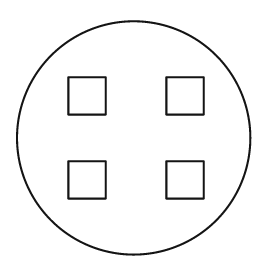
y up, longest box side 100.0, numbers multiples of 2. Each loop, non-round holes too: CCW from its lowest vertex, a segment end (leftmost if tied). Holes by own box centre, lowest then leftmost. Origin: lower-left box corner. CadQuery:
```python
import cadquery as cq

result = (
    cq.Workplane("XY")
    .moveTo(50.0, 50.0)
    .circle(50.0)
    .moveTo(22.0, 24.0)
    .lineTo(38.0, 24.0)
    .lineTo(38.0, 40.0)
    .lineTo(22.0, 40.0)
    .close()
    .moveTo(64.0, 24.0)
    .lineTo(80.0, 24.0)
    .lineTo(80.0, 40.0)
    .lineTo(64.0, 40.0)
    .close()
    .moveTo(22.0, 60.0)
    .lineTo(38.0, 60.0)
    .lineTo(38.0, 76.0)
    .lineTo(22.0, 76.0)
    .close()
    .moveTo(64.0, 60.0)
    .lineTo(80.0, 60.0)
    .lineTo(80.0, 76.0)
    .lineTo(64.0, 76.0)
    .close()
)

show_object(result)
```